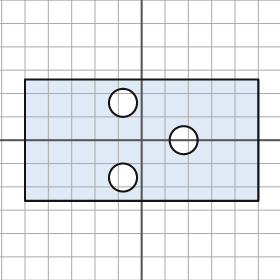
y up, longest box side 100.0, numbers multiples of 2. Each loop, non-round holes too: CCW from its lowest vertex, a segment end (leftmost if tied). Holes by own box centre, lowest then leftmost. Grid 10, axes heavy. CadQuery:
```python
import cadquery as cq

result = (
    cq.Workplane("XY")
    .moveTo(-50.0, -26.0)
    .lineTo(50.0, -26.0)
    .lineTo(50.0, 26.0)
    .lineTo(-50.0, 26.0)
    .close()
    .moveTo(-8.0, -16.0)
    .circle(6.0)
    .moveTo(18.0, 0.0)
    .circle(6.0)
    .moveTo(-8.0, 16.0)
    .circle(6.0)
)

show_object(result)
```